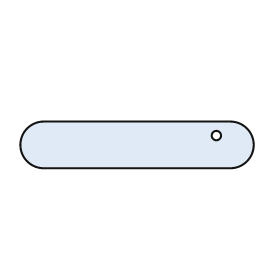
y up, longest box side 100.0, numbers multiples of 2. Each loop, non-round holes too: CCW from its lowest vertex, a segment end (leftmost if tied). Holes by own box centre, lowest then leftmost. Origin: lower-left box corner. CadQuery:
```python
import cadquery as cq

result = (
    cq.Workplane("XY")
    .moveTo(10.0, 0.0)
    .lineTo(90.0, 0.0)
    .threePointArc((100.0, 10.0), (90.0, 20.0))
    .lineTo(10.0, 20.0)
    .threePointArc((0.0, 10.0), (10.0, 0.0))
    .close()
    .moveTo(84.0, 14.0)
    .circle(2.0)
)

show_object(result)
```